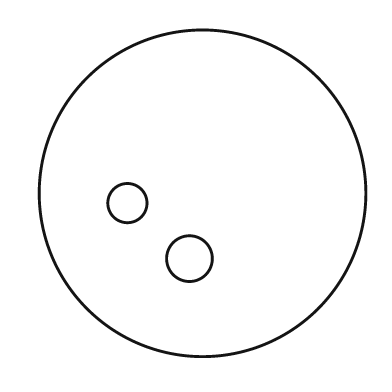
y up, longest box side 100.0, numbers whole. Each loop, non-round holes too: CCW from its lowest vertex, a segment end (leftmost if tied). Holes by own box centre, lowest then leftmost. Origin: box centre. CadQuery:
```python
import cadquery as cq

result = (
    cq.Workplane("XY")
    .moveTo(0.0, 0.0)
    .circle(50.0)
    .moveTo(-4.0, -20.0)
    .circle(7.0)
    .moveTo(-23.0, -3.0)
    .circle(6.0)
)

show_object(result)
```